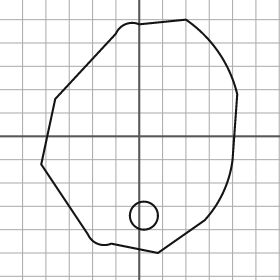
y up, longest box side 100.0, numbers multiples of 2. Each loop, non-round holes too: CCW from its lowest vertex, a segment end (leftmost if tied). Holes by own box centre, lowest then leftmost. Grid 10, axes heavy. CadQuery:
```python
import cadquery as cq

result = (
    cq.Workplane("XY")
    .moveTo(8.0, -50.0)
    .lineTo(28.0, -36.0)
    .threePointArc((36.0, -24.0), (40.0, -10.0))
    .lineTo(42.0, 18.0)
    .threePointArc((34.0, 36.0), (20.0, 50.0))
    .lineTo(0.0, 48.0)
    .threePointArc((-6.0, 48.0), (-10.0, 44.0))
    .lineTo(-36.0, 16.0)
    .lineTo(-42.0, -12.0)
    .lineTo(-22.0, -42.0)
    .threePointArc((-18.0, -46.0), (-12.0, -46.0))
    .close()
    .moveTo(2.0, -34.0)
    .circle(6.0)
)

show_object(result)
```